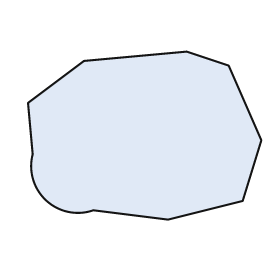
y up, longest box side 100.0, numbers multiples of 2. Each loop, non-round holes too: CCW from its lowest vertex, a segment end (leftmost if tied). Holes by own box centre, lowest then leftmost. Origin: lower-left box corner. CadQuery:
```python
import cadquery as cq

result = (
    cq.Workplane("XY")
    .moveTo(60.0, 0.0)
    .lineTo(92.0, 8.0)
    .lineTo(100.0, 34.0)
    .lineTo(86.0, 66.0)
    .lineTo(68.0, 72.0)
    .lineTo(24.0, 68.0)
    .lineTo(0.0, 50.0)
    .lineTo(2.0, 28.0)
    .threePointArc((8.0, 8.0), (28.0, 4.0))
    .close()
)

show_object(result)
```